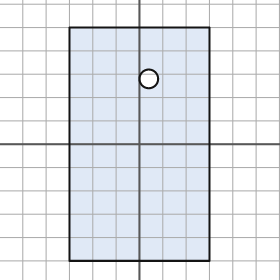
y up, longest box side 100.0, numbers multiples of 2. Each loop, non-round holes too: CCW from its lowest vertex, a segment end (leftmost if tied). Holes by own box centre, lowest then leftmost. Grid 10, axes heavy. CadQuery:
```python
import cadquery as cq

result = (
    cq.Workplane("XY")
    .moveTo(-30.0, -50.0)
    .lineTo(30.0, -50.0)
    .lineTo(30.0, 50.0)
    .lineTo(-30.0, 50.0)
    .close()
    .moveTo(4.0, 28.0)
    .circle(4.0)
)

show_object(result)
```